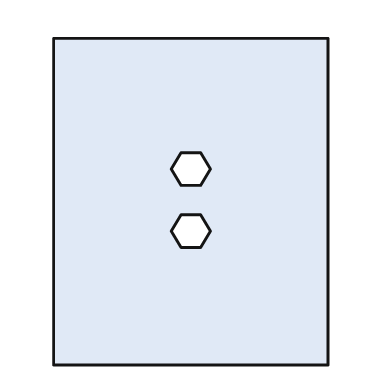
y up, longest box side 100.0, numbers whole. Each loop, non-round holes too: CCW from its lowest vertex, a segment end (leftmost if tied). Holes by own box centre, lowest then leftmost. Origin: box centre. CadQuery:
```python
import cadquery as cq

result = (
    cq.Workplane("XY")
    .moveTo(-42.0, -50.0)
    .lineTo(42.0, -50.0)
    .lineTo(42.0, 50.0)
    .lineTo(-42.0, 50.0)
    .close()
    .moveTo(-3.0, -14.0)
    .lineTo(3.0, -14.0)
    .lineTo(6.0, -9.0)
    .lineTo(3.0, -4.0)
    .lineTo(-3.0, -4.0)
    .lineTo(-6.0, -9.0)
    .close()
    .moveTo(-3.0, 5.0)
    .lineTo(3.0, 5.0)
    .lineTo(6.0, 10.0)
    .lineTo(3.0, 15.0)
    .lineTo(-3.0, 15.0)
    .lineTo(-6.0, 10.0)
    .close()
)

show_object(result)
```